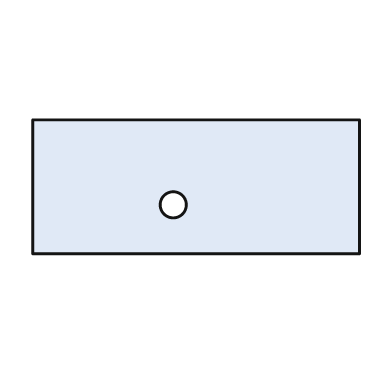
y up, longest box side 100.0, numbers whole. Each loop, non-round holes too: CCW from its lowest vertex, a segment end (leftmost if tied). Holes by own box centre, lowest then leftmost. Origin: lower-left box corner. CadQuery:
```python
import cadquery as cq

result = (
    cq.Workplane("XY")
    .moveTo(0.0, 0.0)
    .lineTo(100.0, 0.0)
    .lineTo(100.0, 41.0)
    .lineTo(0.0, 41.0)
    .close()
    .moveTo(43.0, 15.0)
    .circle(4.0)
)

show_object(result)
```